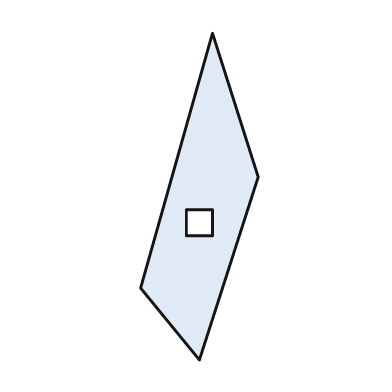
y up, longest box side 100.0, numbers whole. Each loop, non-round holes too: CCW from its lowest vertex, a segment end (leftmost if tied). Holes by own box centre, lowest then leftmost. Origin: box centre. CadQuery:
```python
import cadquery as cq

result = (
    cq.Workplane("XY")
    .moveTo(0.0, -50.0)
    .lineTo(18.0, 6.0)
    .lineTo(4.0, 50.0)
    .lineTo(-18.0, -28.0)
    .close()
    .moveTo(-4.0, -12.0)
    .lineTo(4.0, -12.0)
    .lineTo(4.0, -4.0)
    .lineTo(-4.0, -4.0)
    .close()
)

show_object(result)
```